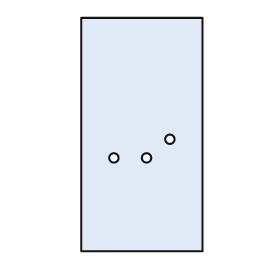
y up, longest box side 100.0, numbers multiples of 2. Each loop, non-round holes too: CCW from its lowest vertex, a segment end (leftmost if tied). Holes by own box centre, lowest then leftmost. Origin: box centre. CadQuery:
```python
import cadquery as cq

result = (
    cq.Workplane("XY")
    .moveTo(-26.0, -50.0)
    .lineTo(26.0, -50.0)
    .lineTo(26.0, 50.0)
    .lineTo(-26.0, 50.0)
    .close()
    .moveTo(-12.0, -10.0)
    .circle(2.0)
    .moveTo(2.0, -10.0)
    .circle(2.0)
    .moveTo(12.0, -2.0)
    .circle(2.0)
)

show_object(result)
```